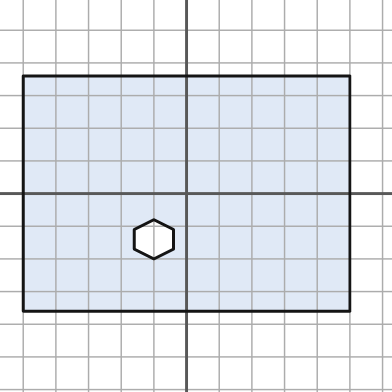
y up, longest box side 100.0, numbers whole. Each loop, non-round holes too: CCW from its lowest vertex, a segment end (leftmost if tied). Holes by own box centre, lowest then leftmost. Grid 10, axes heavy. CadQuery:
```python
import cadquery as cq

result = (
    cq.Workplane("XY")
    .moveTo(-50.0, -36.0)
    .lineTo(50.0, -36.0)
    .lineTo(50.0, 36.0)
    .lineTo(-50.0, 36.0)
    .close()
    .moveTo(-10.0, -20.0)
    .lineTo(-4.0, -17.0)
    .lineTo(-4.0, -11.0)
    .lineTo(-10.0, -8.0)
    .lineTo(-16.0, -11.0)
    .lineTo(-16.0, -17.0)
    .close()
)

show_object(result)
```